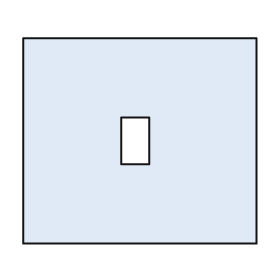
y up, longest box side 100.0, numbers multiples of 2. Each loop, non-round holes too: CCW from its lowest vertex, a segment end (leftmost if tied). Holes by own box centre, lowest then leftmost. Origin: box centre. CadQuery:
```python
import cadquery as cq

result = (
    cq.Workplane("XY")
    .moveTo(-50.0, -44.0)
    .lineTo(50.0, -44.0)
    .lineTo(50.0, 44.0)
    .lineTo(-50.0, 44.0)
    .close()
    .moveTo(-8.0, -10.0)
    .lineTo(4.0, -10.0)
    .lineTo(4.0, 10.0)
    .lineTo(-8.0, 10.0)
    .close()
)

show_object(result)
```